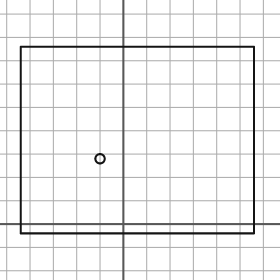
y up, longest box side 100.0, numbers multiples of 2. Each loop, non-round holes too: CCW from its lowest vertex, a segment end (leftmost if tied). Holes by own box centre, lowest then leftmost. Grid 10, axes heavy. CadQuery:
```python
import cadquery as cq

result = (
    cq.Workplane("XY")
    .moveTo(-44.0, -4.0)
    .lineTo(56.0, -4.0)
    .lineTo(56.0, 76.0)
    .lineTo(-44.0, 76.0)
    .close()
    .moveTo(-10.0, 28.0)
    .circle(2.0)
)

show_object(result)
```